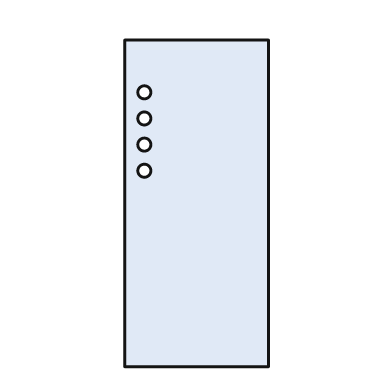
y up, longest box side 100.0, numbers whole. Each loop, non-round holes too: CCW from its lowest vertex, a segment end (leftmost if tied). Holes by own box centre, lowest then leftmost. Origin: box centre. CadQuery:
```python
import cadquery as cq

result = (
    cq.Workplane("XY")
    .moveTo(-22.0, -50.0)
    .lineTo(22.0, -50.0)
    .lineTo(22.0, 50.0)
    .lineTo(-22.0, 50.0)
    .close()
    .moveTo(-16.0, 10.0)
    .circle(2.0)
    .moveTo(-16.0, 18.0)
    .circle(2.0)
    .moveTo(-16.0, 26.0)
    .circle(2.0)
    .moveTo(-16.0, 34.0)
    .circle(2.0)
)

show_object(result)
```